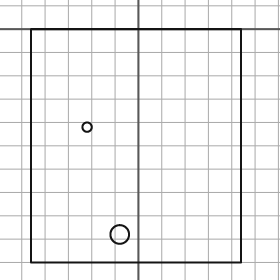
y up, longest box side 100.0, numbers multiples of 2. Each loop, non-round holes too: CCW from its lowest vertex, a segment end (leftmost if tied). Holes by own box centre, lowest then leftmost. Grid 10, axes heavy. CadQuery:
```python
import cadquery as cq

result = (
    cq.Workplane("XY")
    .moveTo(-46.0, -100.0)
    .lineTo(44.0, -100.0)
    .lineTo(44.0, 0.0)
    .lineTo(-46.0, 0.0)
    .close()
    .moveTo(-8.0, -88.0)
    .circle(4.0)
    .moveTo(-22.0, -42.0)
    .circle(2.0)
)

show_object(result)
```